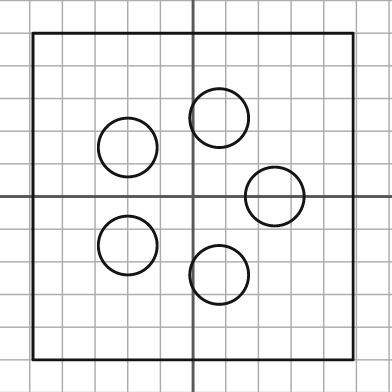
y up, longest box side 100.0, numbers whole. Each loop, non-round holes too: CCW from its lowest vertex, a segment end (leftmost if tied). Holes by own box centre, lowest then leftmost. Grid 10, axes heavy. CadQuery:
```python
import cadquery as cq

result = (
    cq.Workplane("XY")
    .moveTo(-49.0, -50.0)
    .lineTo(49.0, -50.0)
    .lineTo(49.0, 50.0)
    .lineTo(-49.0, 50.0)
    .close()
    .moveTo(8.0, -24.0)
    .circle(9.0)
    .moveTo(-20.0, -15.0)
    .circle(9.0)
    .moveTo(25.0, 0.0)
    .circle(9.0)
    .moveTo(-20.0, 15.0)
    .circle(9.0)
    .moveTo(8.0, 24.0)
    .circle(9.0)
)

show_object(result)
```